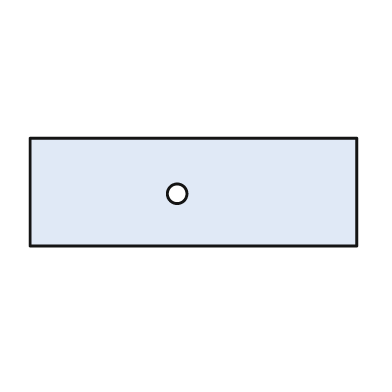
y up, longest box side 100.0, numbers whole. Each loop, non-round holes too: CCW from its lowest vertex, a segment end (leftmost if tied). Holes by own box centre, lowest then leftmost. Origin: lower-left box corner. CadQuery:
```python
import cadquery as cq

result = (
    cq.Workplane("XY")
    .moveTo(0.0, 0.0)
    .lineTo(100.0, 0.0)
    .lineTo(100.0, 33.0)
    .lineTo(0.0, 33.0)
    .close()
    .moveTo(45.0, 16.0)
    .circle(3.0)
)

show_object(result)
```